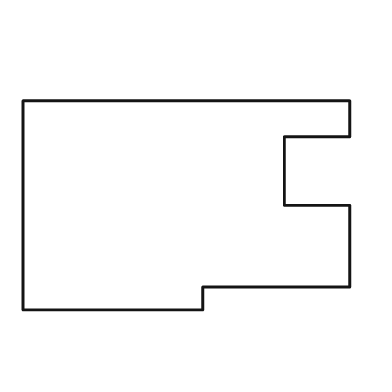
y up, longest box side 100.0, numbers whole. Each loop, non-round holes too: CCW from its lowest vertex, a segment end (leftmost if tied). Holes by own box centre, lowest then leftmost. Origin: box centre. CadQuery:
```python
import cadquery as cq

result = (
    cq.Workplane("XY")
    .moveTo(-50.0, -32.0)
    .lineTo(5.0, -32.0)
    .lineTo(5.0, -25.0)
    .lineTo(50.0, -25.0)
    .lineTo(50.0, 0.0)
    .lineTo(30.0, 0.0)
    .lineTo(30.0, 21.0)
    .lineTo(50.0, 21.0)
    .lineTo(50.0, 32.0)
    .lineTo(-50.0, 32.0)
    .close()
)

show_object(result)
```